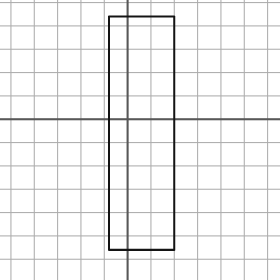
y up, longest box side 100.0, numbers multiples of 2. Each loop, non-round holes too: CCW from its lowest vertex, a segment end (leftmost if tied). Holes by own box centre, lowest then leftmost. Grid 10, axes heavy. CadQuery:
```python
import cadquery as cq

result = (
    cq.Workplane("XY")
    .moveTo(-8.0, -56.0)
    .lineTo(20.0, -56.0)
    .lineTo(20.0, 44.0)
    .lineTo(-8.0, 44.0)
    .close()
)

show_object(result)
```